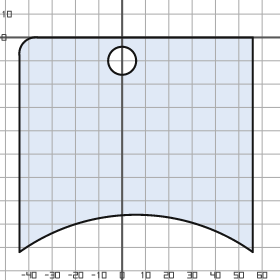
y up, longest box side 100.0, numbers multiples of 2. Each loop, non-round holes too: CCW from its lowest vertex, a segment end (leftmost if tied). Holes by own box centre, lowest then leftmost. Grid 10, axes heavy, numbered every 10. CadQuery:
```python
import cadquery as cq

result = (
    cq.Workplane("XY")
    .moveTo(-44.0, -92.0)
    .threePointArc((6.0, -76.0), (56.0, -92.0))
    .lineTo(56.0, 0.0)
    .lineTo(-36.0, 0.0)
    .threePointArc((-42.0, -2.0), (-44.0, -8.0))
    .close()
    .moveTo(0.0, -10.0)
    .circle(6.0)
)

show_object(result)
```